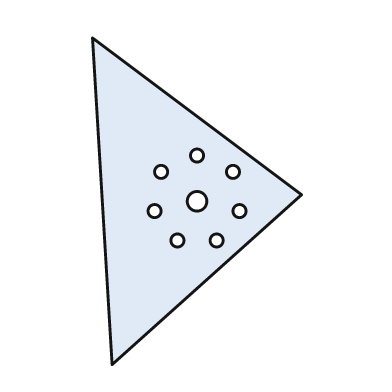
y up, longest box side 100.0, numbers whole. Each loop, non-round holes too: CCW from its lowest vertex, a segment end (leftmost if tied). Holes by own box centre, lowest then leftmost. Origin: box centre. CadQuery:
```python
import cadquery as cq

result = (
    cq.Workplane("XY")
    .moveTo(-26.0, -50.0)
    .lineTo(32.0, 2.0)
    .lineTo(-32.0, 50.0)
    .close()
    .moveTo(-6.0, -12.0)
    .circle(2.0)
    .moveTo(6.0, -12.0)
    .circle(2.0)
    .moveTo(-13.0, -3.0)
    .circle(2.0)
    .moveTo(13.0, -3.0)
    .circle(2.0)
    .moveTo(0.0, 0.0)
    .circle(3.0)
    .moveTo(-11.0, 9.0)
    .circle(2.0)
    .moveTo(11.0, 9.0)
    .circle(2.0)
    .moveTo(0.0, 14.0)
    .circle(2.0)
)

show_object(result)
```